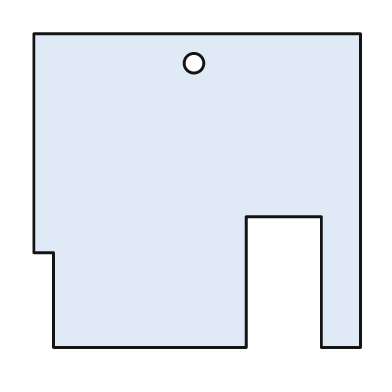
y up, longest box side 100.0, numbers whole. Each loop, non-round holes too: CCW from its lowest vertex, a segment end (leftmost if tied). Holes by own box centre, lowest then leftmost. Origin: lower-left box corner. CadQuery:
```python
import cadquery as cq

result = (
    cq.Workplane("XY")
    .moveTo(6.0, 0.0)
    .lineTo(65.0, 0.0)
    .lineTo(65.0, 40.0)
    .lineTo(88.0, 40.0)
    .lineTo(88.0, 0.0)
    .lineTo(100.0, 0.0)
    .lineTo(100.0, 96.0)
    .lineTo(0.0, 96.0)
    .lineTo(0.0, 29.0)
    .lineTo(6.0, 29.0)
    .close()
    .moveTo(49.0, 87.0)
    .circle(3.0)
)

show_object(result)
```